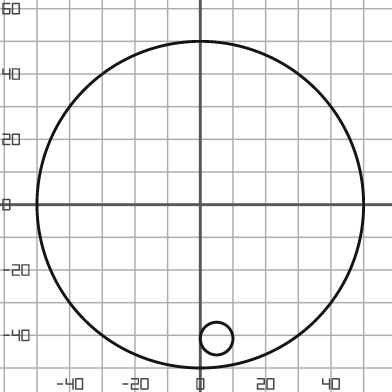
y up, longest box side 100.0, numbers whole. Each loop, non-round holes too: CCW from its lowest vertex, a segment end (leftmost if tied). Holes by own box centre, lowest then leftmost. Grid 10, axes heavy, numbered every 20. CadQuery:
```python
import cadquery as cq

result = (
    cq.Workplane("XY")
    .moveTo(0.0, 0.0)
    .circle(50.0)
    .moveTo(5.0, -41.0)
    .circle(5.0)
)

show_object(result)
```